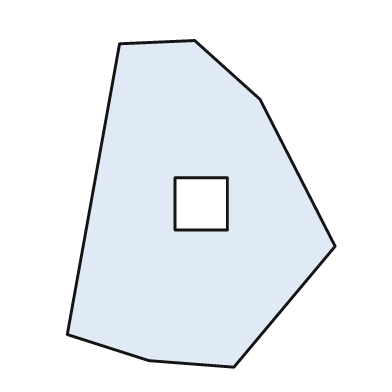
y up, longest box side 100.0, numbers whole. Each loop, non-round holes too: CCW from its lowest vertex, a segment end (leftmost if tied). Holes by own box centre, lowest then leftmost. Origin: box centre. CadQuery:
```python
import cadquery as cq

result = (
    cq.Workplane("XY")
    .moveTo(10.0, -50.0)
    .lineTo(41.0, -13.0)
    .lineTo(18.0, 32.0)
    .lineTo(-2.0, 50.0)
    .lineTo(-25.0, 49.0)
    .lineTo(-41.0, -40.0)
    .lineTo(-16.0, -48.0)
    .close()
    .moveTo(-8.0, -8.0)
    .lineTo(8.0, -8.0)
    .lineTo(8.0, 8.0)
    .lineTo(-8.0, 8.0)
    .close()
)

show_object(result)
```